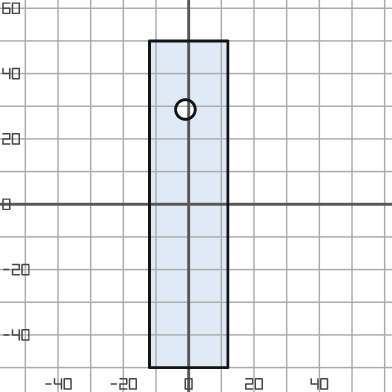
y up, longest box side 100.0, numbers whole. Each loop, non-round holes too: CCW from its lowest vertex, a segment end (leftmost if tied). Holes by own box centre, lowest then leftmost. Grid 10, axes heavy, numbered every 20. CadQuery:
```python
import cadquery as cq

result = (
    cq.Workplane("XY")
    .moveTo(-12.0, -50.0)
    .lineTo(12.0, -50.0)
    .lineTo(12.0, 50.0)
    .lineTo(-12.0, 50.0)
    .close()
    .moveTo(-1.0, 29.0)
    .circle(3.0)
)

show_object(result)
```